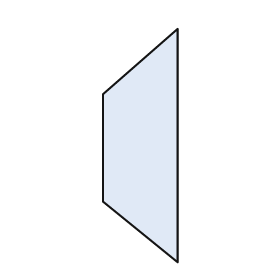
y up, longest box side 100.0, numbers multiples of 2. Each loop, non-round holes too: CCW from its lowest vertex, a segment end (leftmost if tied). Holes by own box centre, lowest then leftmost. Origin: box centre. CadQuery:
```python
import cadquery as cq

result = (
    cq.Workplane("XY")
    .moveTo(16.0, -50.0)
    .lineTo(16.0, 50.0)
    .lineTo(-16.0, 22.0)
    .lineTo(-16.0, -24.0)
    .close()
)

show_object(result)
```